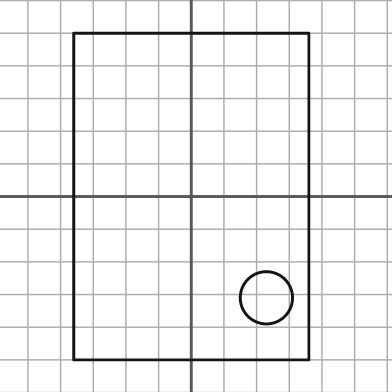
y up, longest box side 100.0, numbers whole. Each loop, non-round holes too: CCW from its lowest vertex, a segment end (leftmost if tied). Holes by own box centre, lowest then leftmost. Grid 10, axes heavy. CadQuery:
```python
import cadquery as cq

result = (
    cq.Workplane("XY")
    .moveTo(-36.0, -50.0)
    .lineTo(36.0, -50.0)
    .lineTo(36.0, 50.0)
    .lineTo(-36.0, 50.0)
    .close()
    .moveTo(23.0, -31.0)
    .circle(8.0)
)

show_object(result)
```